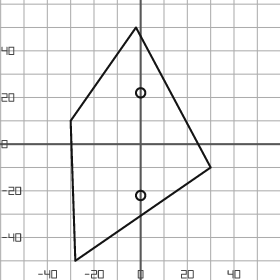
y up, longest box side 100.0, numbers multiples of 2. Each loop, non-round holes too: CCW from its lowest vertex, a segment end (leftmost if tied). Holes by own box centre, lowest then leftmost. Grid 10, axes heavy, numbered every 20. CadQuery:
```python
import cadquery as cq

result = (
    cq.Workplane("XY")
    .moveTo(-28.0, -50.0)
    .lineTo(30.0, -10.0)
    .lineTo(-2.0, 50.0)
    .lineTo(-30.0, 10.0)
    .close()
    .moveTo(0.0, -22.0)
    .circle(2.0)
    .moveTo(0.0, 22.0)
    .circle(2.0)
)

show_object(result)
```